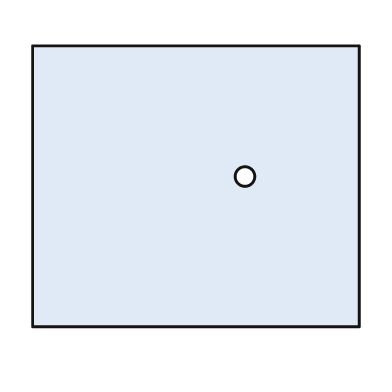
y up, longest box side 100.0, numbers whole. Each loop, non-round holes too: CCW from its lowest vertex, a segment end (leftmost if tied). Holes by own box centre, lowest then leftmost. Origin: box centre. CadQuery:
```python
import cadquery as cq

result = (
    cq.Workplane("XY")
    .moveTo(-50.0, -43.0)
    .lineTo(50.0, -43.0)
    .lineTo(50.0, 43.0)
    .lineTo(-50.0, 43.0)
    .close()
    .moveTo(15.0, 3.0)
    .circle(3.0)
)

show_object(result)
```